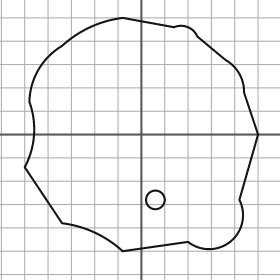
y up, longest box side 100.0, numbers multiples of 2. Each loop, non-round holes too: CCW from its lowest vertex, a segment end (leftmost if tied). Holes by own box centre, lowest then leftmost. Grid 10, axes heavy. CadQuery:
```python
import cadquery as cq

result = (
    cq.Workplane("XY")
    .moveTo(-8.0, -50.0)
    .lineTo(20.0, -46.0)
    .threePointArc((38.0, -46.0), (42.0, -28.0))
    .lineTo(50.0, 0.0)
    .lineTo(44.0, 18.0)
    .threePointArc((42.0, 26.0), (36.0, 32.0))
    .lineTo(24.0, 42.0)
    .threePointArc((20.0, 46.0), (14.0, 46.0))
    .lineTo(-8.0, 50.0)
    .threePointArc((-22.0, 46.0), (-34.0, 38.0))
    .threePointArc((-44.0, 28.0), (-48.0, 14.0))
    .threePointArc((-46.0, 0.0), (-50.0, -14.0))
    .lineTo(-34.0, -38.0)
    .threePointArc((-20.0, -42.0), (-8.0, -50.0))
    .close()
    .moveTo(6.0, -28.0)
    .circle(4.0)
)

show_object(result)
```